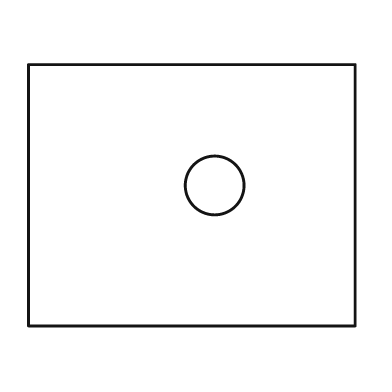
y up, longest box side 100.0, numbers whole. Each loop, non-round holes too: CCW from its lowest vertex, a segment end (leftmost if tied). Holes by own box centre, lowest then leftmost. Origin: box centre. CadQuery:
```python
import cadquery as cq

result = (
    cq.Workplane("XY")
    .moveTo(-50.0, -40.0)
    .lineTo(50.0, -40.0)
    .lineTo(50.0, 40.0)
    .lineTo(-50.0, 40.0)
    .close()
    .moveTo(7.0, 3.0)
    .circle(9.0)
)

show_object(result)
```